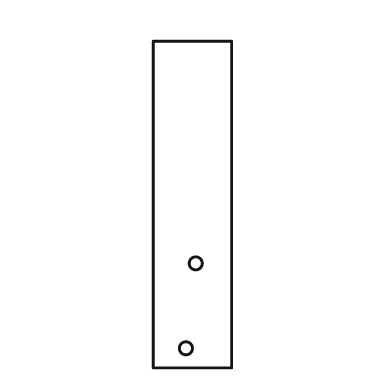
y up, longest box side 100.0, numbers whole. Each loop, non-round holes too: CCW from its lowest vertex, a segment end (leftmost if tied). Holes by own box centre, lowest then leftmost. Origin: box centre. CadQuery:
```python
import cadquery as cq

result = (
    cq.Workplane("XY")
    .moveTo(-12.0, -50.0)
    .lineTo(12.0, -50.0)
    .lineTo(12.0, 50.0)
    .lineTo(-12.0, 50.0)
    .close()
    .moveTo(-2.0, -44.0)
    .circle(2.0)
    .moveTo(1.0, -18.0)
    .circle(2.0)
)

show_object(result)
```